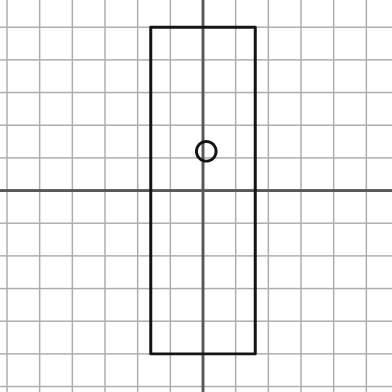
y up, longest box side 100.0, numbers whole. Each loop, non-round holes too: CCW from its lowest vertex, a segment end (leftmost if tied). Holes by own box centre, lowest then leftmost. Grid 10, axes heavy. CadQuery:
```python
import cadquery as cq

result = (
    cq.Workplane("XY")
    .moveTo(-16.0, -50.0)
    .lineTo(16.0, -50.0)
    .lineTo(16.0, 50.0)
    .lineTo(-16.0, 50.0)
    .close()
    .moveTo(1.0, 12.0)
    .circle(3.0)
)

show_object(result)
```